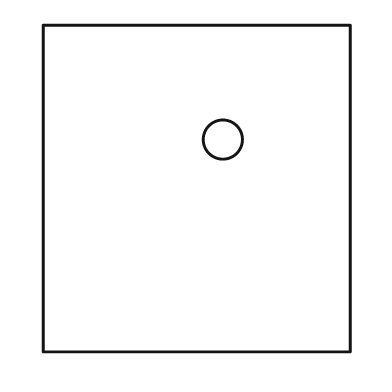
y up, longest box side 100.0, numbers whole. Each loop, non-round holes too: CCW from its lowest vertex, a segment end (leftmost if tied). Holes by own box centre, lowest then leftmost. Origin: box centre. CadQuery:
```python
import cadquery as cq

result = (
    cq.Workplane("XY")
    .moveTo(-47.0, -50.0)
    .lineTo(47.0, -50.0)
    .lineTo(47.0, 50.0)
    .lineTo(-47.0, 50.0)
    .close()
    .moveTo(8.0, 15.0)
    .circle(6.0)
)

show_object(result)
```